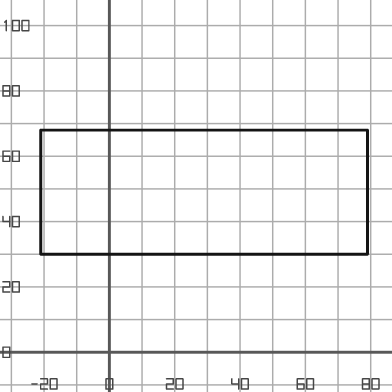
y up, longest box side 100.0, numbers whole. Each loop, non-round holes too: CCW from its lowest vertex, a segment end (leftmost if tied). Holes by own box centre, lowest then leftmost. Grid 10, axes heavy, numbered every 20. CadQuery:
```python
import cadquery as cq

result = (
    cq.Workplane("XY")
    .moveTo(-21.0, 30.0)
    .lineTo(79.0, 30.0)
    .lineTo(79.0, 68.0)
    .lineTo(-21.0, 68.0)
    .close()
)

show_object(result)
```